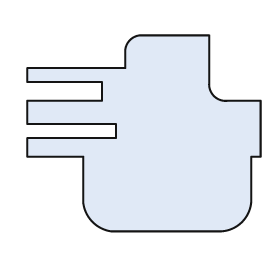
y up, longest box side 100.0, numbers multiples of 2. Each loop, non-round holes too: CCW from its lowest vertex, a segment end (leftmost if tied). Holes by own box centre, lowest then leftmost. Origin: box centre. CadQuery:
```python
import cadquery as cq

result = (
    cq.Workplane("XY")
    .moveTo(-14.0, -42.0)
    .lineTo(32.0, -42.0)
    .threePointArc((42.0, -38.0), (46.0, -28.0))
    .lineTo(46.0, -10.0)
    .lineTo(50.0, -10.0)
    .lineTo(50.0, 14.0)
    .lineTo(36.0, 14.0)
    .threePointArc((30.0, 16.0), (28.0, 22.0))
    .lineTo(28.0, 42.0)
    .lineTo(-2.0, 42.0)
    .threePointArc((-6.0, 40.0), (-8.0, 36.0))
    .lineTo(-8.0, 28.0)
    .lineTo(-50.0, 28.0)
    .lineTo(-50.0, 22.0)
    .lineTo(-18.0, 22.0)
    .lineTo(-18.0, 14.0)
    .lineTo(-50.0, 14.0)
    .lineTo(-50.0, 4.0)
    .lineTo(-12.0, 4.0)
    .lineTo(-12.0, -2.0)
    .lineTo(-50.0, -2.0)
    .lineTo(-50.0, -10.0)
    .lineTo(-26.0, -10.0)
    .lineTo(-26.0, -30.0)
    .threePointArc((-22.0, -38.0), (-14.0, -42.0))
    .close()
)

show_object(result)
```